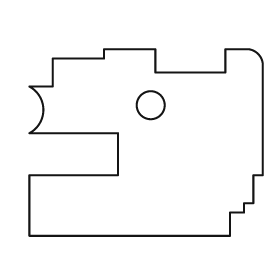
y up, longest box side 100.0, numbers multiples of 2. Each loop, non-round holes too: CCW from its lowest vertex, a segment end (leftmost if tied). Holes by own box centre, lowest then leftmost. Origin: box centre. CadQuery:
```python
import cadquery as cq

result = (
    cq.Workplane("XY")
    .moveTo(-50.0, -40.0)
    .lineTo(36.0, -40.0)
    .lineTo(36.0, -30.0)
    .lineTo(42.0, -30.0)
    .lineTo(42.0, -26.0)
    .lineTo(46.0, -26.0)
    .lineTo(46.0, -14.0)
    .lineTo(50.0, -14.0)
    .lineTo(50.0, 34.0)
    .threePointArc((48.0, 38.0), (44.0, 40.0))
    .lineTo(34.0, 40.0)
    .lineTo(34.0, 30.0)
    .lineTo(4.0, 30.0)
    .lineTo(4.0, 40.0)
    .lineTo(-18.0, 40.0)
    .lineTo(-18.0, 36.0)
    .lineTo(-40.0, 36.0)
    .lineTo(-40.0, 24.0)
    .lineTo(-50.0, 24.0)
    .threePointArc((-44.0, 14.0), (-50.0, 4.0))
    .lineTo(-12.0, 4.0)
    .lineTo(-12.0, -14.0)
    .lineTo(-50.0, -14.0)
    .close()
    .moveTo(2.0, 16.0)
    .circle(6.0)
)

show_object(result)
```